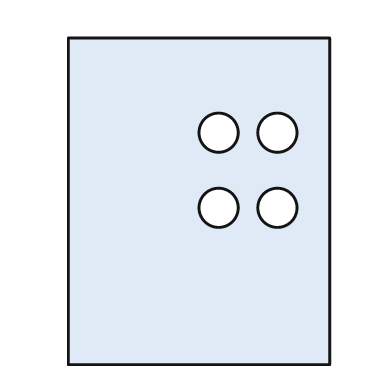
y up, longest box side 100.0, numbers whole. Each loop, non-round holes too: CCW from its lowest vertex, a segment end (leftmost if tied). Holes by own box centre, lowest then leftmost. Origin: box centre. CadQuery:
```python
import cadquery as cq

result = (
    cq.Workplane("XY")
    .moveTo(-40.0, -50.0)
    .lineTo(40.0, -50.0)
    .lineTo(40.0, 50.0)
    .lineTo(-40.0, 50.0)
    .close()
    .moveTo(6.0, -2.0)
    .circle(6.0)
    .moveTo(24.0, -2.0)
    .circle(6.0)
    .moveTo(6.0, 21.0)
    .circle(6.0)
    .moveTo(24.0, 21.0)
    .circle(6.0)
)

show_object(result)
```